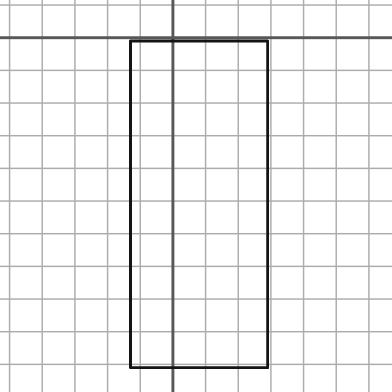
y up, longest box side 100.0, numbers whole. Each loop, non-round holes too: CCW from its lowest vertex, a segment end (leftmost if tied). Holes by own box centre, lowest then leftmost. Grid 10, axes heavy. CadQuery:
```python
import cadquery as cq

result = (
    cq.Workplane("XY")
    .moveTo(-13.0, -101.0)
    .lineTo(29.0, -101.0)
    .lineTo(29.0, -1.0)
    .lineTo(-13.0, -1.0)
    .close()
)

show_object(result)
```